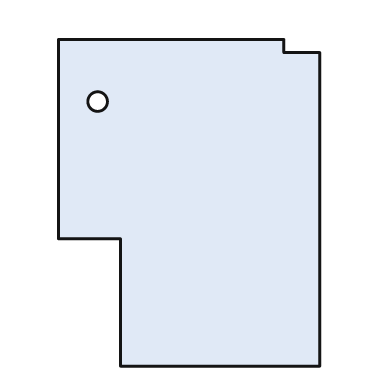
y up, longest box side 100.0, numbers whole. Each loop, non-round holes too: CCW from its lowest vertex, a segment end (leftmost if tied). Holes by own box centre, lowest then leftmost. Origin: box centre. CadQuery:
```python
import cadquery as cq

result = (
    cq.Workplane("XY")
    .moveTo(-21.0, -50.0)
    .lineTo(40.0, -50.0)
    .lineTo(40.0, 46.0)
    .lineTo(29.0, 46.0)
    .lineTo(29.0, 50.0)
    .lineTo(-40.0, 50.0)
    .lineTo(-40.0, -11.0)
    .lineTo(-21.0, -11.0)
    .close()
    .moveTo(-28.0, 31.0)
    .circle(3.0)
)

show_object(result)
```